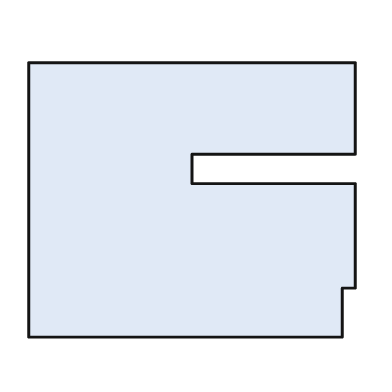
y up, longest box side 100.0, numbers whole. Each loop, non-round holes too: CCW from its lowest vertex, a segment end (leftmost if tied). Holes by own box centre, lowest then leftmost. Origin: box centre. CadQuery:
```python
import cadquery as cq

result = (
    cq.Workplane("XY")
    .moveTo(-50.0, -42.0)
    .lineTo(46.0, -42.0)
    .lineTo(46.0, -27.0)
    .lineTo(50.0, -27.0)
    .lineTo(50.0, 5.0)
    .lineTo(0.0, 5.0)
    .lineTo(0.0, 14.0)
    .lineTo(50.0, 14.0)
    .lineTo(50.0, 42.0)
    .lineTo(-50.0, 42.0)
    .close()
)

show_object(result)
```